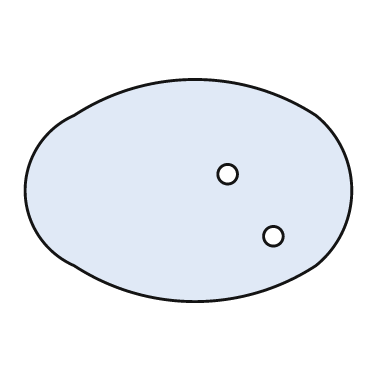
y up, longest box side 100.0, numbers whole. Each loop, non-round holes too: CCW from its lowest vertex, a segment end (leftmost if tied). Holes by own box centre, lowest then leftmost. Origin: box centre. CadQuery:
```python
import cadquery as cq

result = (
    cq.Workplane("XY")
    .moveTo(-35.0, -23.0)
    .threePointArc((2.0, -34.0), (39.0, -23.0))
    .threePointArc((50.0, 0.0), (39.0, 23.0))
    .threePointArc((2.0, 34.0), (-35.0, 23.0))
    .threePointArc((-50.0, 0.0), (-35.0, -23.0))
    .close()
    .moveTo(26.0, -14.0)
    .circle(3.0)
    .moveTo(12.0, 5.0)
    .circle(3.0)
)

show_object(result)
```